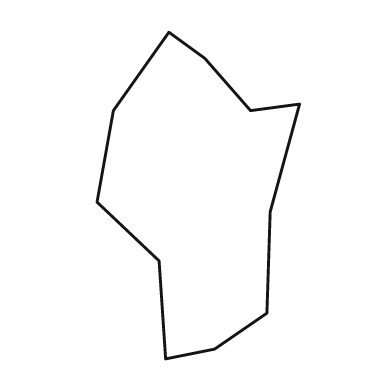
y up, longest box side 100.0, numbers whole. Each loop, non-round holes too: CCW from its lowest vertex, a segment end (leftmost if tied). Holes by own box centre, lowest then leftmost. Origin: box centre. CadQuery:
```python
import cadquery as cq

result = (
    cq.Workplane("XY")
    .moveTo(-10.0, -50.0)
    .lineTo(5.0, -47.0)
    .lineTo(21.0, -36.0)
    .lineTo(22.0, -5.0)
    .lineTo(31.0, 28.0)
    .lineTo(16.0, 26.0)
    .lineTo(2.0, 42.0)
    .lineTo(-9.0, 50.0)
    .lineTo(-26.0, 26.0)
    .lineTo(-31.0, -2.0)
    .lineTo(-12.0, -20.0)
    .close()
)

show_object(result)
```